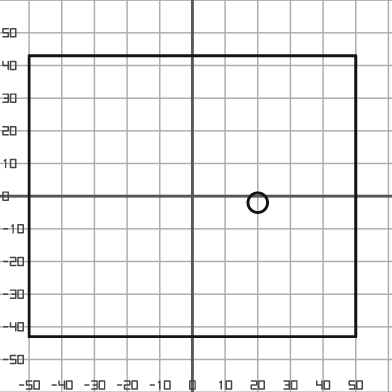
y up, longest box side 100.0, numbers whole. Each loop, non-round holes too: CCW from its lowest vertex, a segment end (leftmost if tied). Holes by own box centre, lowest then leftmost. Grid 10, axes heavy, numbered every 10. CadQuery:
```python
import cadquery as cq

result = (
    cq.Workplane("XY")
    .moveTo(-50.0, -43.0)
    .lineTo(50.0, -43.0)
    .lineTo(50.0, 43.0)
    .lineTo(-50.0, 43.0)
    .close()
    .moveTo(20.0, -2.0)
    .circle(3.0)
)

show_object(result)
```